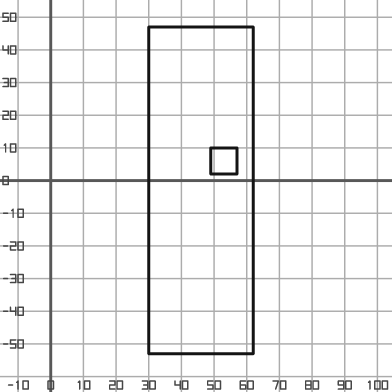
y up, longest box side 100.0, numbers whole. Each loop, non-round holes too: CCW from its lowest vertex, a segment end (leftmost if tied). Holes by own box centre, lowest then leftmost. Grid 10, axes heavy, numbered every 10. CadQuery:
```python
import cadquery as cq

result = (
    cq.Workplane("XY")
    .moveTo(30.0, -53.0)
    .lineTo(62.0, -53.0)
    .lineTo(62.0, 47.0)
    .lineTo(30.0, 47.0)
    .close()
    .moveTo(49.0, 2.0)
    .lineTo(57.0, 2.0)
    .lineTo(57.0, 10.0)
    .lineTo(49.0, 10.0)
    .close()
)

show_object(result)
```